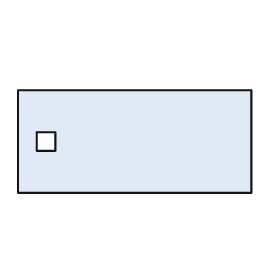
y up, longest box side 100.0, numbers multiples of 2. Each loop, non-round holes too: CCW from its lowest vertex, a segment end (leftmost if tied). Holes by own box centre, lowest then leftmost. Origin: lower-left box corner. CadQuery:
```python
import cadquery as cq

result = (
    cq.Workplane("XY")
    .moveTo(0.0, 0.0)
    .lineTo(100.0, 0.0)
    .lineTo(100.0, 44.0)
    .lineTo(0.0, 44.0)
    .close()
    .moveTo(8.0, 18.0)
    .lineTo(16.0, 18.0)
    .lineTo(16.0, 26.0)
    .lineTo(8.0, 26.0)
    .close()
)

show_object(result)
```